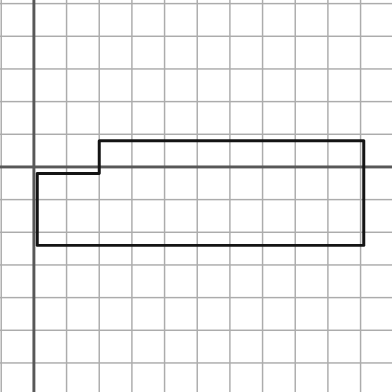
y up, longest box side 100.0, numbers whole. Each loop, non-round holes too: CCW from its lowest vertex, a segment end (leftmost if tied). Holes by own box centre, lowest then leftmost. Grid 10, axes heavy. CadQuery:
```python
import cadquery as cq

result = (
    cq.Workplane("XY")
    .moveTo(1.0, -24.0)
    .lineTo(101.0, -24.0)
    .lineTo(101.0, 8.0)
    .lineTo(20.0, 8.0)
    .lineTo(20.0, -2.0)
    .lineTo(1.0, -2.0)
    .close()
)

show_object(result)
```